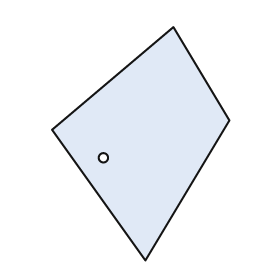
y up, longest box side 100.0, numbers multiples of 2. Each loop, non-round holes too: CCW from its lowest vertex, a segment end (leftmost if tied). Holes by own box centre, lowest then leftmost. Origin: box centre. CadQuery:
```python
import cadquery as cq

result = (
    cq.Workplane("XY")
    .moveTo(2.0, -50.0)
    .lineTo(38.0, 10.0)
    .lineTo(14.0, 50.0)
    .lineTo(-38.0, 6.0)
    .close()
    .moveTo(-16.0, -6.0)
    .circle(2.0)
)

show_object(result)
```